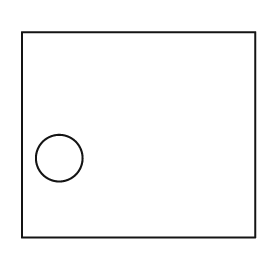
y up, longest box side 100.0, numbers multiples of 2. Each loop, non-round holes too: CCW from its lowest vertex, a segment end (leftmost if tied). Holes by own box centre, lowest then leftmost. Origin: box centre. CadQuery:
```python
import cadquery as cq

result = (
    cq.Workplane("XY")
    .moveTo(-50.0, -44.0)
    .lineTo(50.0, -44.0)
    .lineTo(50.0, 44.0)
    .lineTo(-50.0, 44.0)
    .close()
    .moveTo(-34.0, -10.0)
    .circle(10.0)
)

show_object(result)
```